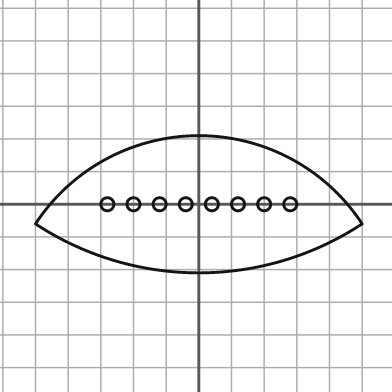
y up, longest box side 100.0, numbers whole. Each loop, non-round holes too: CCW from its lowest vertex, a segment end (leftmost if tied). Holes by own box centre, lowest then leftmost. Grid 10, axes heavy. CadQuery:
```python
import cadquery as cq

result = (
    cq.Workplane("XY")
    .moveTo(-50.0, -6.0)
    .threePointArc((0.0, -21.0), (50.0, -6.0))
    .threePointArc((0.0, 21.0), (-50.0, -6.0))
    .close()
    .moveTo(-28.0, 0.0)
    .circle(2.0)
    .moveTo(-20.0, 0.0)
    .circle(2.0)
    .moveTo(-12.0, 0.0)
    .circle(2.0)
    .moveTo(-4.0, 0.0)
    .circle(2.0)
    .moveTo(4.0, 0.0)
    .circle(2.0)
    .moveTo(12.0, 0.0)
    .circle(2.0)
    .moveTo(20.0, 0.0)
    .circle(2.0)
    .moveTo(28.0, 0.0)
    .circle(2.0)
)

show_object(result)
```